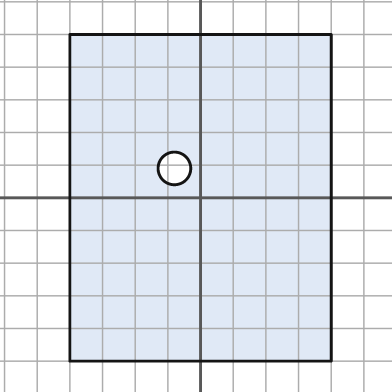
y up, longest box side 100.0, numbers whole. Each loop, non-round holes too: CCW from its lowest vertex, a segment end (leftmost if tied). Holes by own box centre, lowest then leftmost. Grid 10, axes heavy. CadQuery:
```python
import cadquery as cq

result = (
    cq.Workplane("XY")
    .moveTo(-40.0, -50.0)
    .lineTo(40.0, -50.0)
    .lineTo(40.0, 50.0)
    .lineTo(-40.0, 50.0)
    .close()
    .moveTo(-8.0, 9.0)
    .circle(5.0)
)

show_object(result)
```